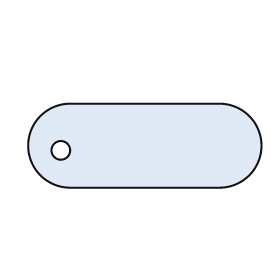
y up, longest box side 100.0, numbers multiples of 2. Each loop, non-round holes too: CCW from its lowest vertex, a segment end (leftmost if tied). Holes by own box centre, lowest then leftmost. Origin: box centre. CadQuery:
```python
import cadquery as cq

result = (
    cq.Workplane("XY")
    .moveTo(-32.0, -18.0)
    .lineTo(32.0, -18.0)
    .threePointArc((50.0, 0.0), (32.0, 18.0))
    .lineTo(-32.0, 18.0)
    .threePointArc((-50.0, 0.0), (-32.0, -18.0))
    .close()
    .moveTo(-36.0, -2.0)
    .circle(4.0)
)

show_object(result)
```